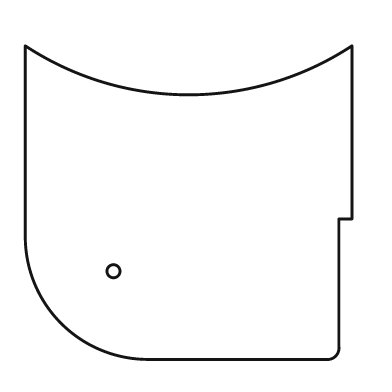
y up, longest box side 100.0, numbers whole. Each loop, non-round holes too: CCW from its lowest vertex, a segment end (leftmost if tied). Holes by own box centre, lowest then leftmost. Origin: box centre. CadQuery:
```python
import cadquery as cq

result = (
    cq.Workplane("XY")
    .moveTo(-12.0, -48.0)
    .lineTo(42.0, -48.0)
    .threePointArc((45.0, -47.0), (46.0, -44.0))
    .lineTo(46.0, -5.0)
    .lineTo(50.0, -5.0)
    .lineTo(50.0, 48.0)
    .threePointArc((0.0, 33.0), (-50.0, 48.0))
    .lineTo(-50.0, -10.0)
    .threePointArc((-39.0, -37.0), (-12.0, -48.0))
    .close()
    .moveTo(-23.0, -21.0)
    .circle(2.0)
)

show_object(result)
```